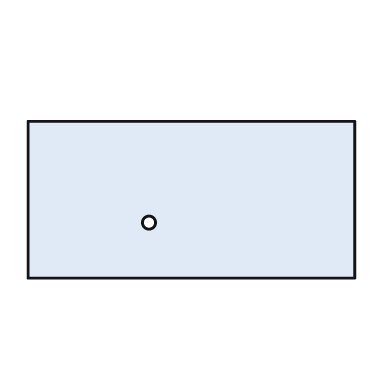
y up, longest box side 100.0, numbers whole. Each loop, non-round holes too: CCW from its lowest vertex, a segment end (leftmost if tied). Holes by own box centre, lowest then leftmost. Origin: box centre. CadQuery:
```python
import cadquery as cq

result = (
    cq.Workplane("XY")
    .moveTo(-50.0, -24.0)
    .lineTo(50.0, -24.0)
    .lineTo(50.0, 24.0)
    .lineTo(-50.0, 24.0)
    .close()
    .moveTo(-13.0, -7.0)
    .circle(2.0)
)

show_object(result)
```